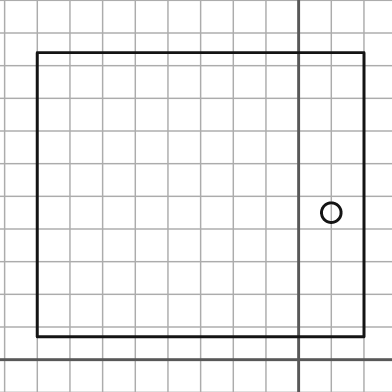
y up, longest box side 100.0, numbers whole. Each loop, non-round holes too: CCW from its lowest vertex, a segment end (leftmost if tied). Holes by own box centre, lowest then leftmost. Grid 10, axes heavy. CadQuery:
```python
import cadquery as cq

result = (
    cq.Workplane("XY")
    .moveTo(-80.0, 7.0)
    .lineTo(20.0, 7.0)
    .lineTo(20.0, 94.0)
    .lineTo(-80.0, 94.0)
    .close()
    .moveTo(10.0, 45.0)
    .circle(3.0)
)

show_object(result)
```